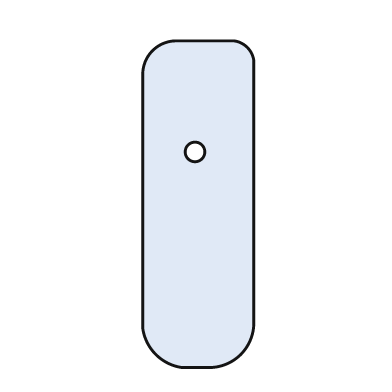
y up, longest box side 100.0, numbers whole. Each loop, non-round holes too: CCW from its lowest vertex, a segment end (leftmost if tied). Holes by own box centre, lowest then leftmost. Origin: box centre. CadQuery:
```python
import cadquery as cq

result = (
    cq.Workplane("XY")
    .moveTo(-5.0, -50.0)
    .lineTo(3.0, -50.0)
    .threePointArc((13.0, -46.0), (17.0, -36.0))
    .lineTo(17.0, 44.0)
    .threePointArc((15.0, 48.0), (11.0, 50.0))
    .lineTo(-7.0, 50.0)
    .threePointArc((-14.0, 47.0), (-17.0, 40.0))
    .lineTo(-17.0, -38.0)
    .threePointArc((-13.0, -46.0), (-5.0, -50.0))
    .close()
    .moveTo(-1.0, 16.0)
    .circle(3.0)
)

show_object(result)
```